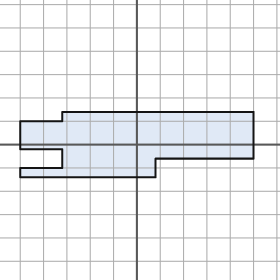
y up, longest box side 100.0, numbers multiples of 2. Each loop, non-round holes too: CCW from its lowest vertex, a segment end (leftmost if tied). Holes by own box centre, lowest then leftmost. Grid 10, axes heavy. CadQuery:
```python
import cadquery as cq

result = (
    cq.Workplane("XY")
    .moveTo(-50.0, -14.0)
    .lineTo(8.0, -14.0)
    .lineTo(8.0, -6.0)
    .lineTo(50.0, -6.0)
    .lineTo(50.0, 14.0)
    .lineTo(-32.0, 14.0)
    .lineTo(-32.0, 10.0)
    .lineTo(-50.0, 10.0)
    .lineTo(-50.0, -2.0)
    .lineTo(-32.0, -2.0)
    .lineTo(-32.0, -10.0)
    .lineTo(-50.0, -10.0)
    .close()
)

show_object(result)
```